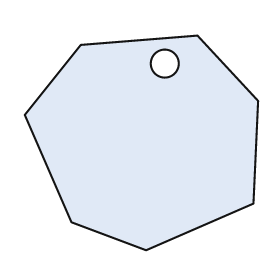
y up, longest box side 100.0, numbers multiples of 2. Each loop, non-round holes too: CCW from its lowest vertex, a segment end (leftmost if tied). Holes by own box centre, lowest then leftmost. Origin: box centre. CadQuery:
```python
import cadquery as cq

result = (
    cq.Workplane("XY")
    .moveTo(2.0, -46.0)
    .lineTo(48.0, -26.0)
    .lineTo(50.0, 18.0)
    .lineTo(24.0, 46.0)
    .lineTo(-26.0, 42.0)
    .lineTo(-50.0, 12.0)
    .lineTo(-30.0, -34.0)
    .close()
    .moveTo(10.0, 34.0)
    .circle(6.0)
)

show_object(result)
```